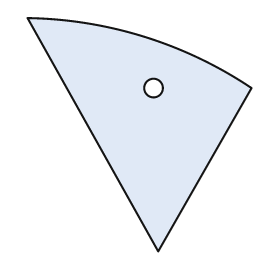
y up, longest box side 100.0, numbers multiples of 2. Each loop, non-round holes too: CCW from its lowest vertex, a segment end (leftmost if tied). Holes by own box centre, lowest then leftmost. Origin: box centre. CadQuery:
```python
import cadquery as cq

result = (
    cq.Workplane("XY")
    .moveTo(8.0, -50.0)
    .lineTo(48.0, 20.0)
    .threePointArc((2.0, 42.0), (-48.0, 50.0))
    .close()
    .moveTo(6.0, 20.0)
    .circle(4.0)
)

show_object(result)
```